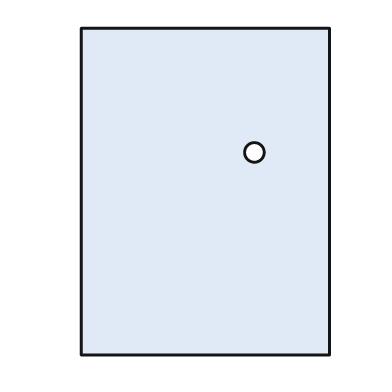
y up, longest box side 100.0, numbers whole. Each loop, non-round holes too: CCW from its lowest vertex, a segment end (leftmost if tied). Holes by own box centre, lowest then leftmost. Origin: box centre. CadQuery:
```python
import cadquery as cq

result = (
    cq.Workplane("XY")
    .moveTo(-38.0, -50.0)
    .lineTo(38.0, -50.0)
    .lineTo(38.0, 50.0)
    .lineTo(-38.0, 50.0)
    .close()
    .moveTo(15.0, 12.0)
    .circle(3.0)
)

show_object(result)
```